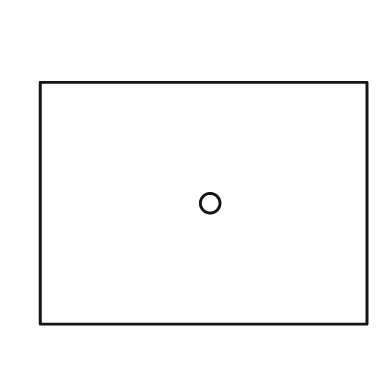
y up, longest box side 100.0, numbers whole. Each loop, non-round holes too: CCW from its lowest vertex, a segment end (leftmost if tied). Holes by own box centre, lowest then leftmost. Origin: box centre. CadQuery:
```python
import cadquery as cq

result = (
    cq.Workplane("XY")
    .moveTo(-50.0, -37.0)
    .lineTo(50.0, -37.0)
    .lineTo(50.0, 37.0)
    .lineTo(-50.0, 37.0)
    .close()
    .moveTo(2.0, 0.0)
    .circle(3.0)
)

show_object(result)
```